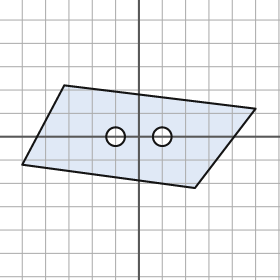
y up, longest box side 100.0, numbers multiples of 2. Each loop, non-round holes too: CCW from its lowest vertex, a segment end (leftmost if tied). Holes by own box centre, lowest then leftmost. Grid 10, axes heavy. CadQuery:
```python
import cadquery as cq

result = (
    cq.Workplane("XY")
    .moveTo(24.0, -22.0)
    .lineTo(50.0, 12.0)
    .lineTo(-32.0, 22.0)
    .lineTo(-50.0, -12.0)
    .close()
    .moveTo(-10.0, 0.0)
    .circle(4.0)
    .moveTo(10.0, 0.0)
    .circle(4.0)
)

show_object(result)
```